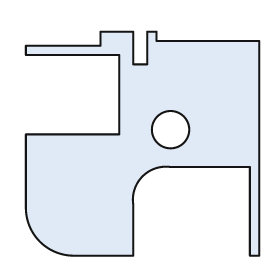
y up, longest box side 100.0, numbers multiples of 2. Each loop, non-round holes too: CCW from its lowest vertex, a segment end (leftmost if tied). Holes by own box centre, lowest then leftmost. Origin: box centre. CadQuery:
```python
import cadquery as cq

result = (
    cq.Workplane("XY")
    .moveTo(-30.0, -48.0)
    .lineTo(-4.0, -48.0)
    .lineTo(-4.0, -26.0)
    .threePointArc((0.0, -14.0), (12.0, -10.0))
    .lineTo(46.0, -10.0)
    .lineTo(46.0, -48.0)
    .lineTo(50.0, -48.0)
    .lineTo(50.0, 44.0)
    .lineTo(6.0, 44.0)
    .lineTo(6.0, 48.0)
    .lineTo(2.0, 48.0)
    .lineTo(2.0, 34.0)
    .lineTo(-4.0, 34.0)
    .lineTo(-4.0, 48.0)
    .lineTo(-18.0, 48.0)
    .lineTo(-18.0, 42.0)
    .lineTo(-50.0, 42.0)
    .lineTo(-50.0, 38.0)
    .lineTo(-10.0, 38.0)
    .lineTo(-10.0, 4.0)
    .lineTo(-50.0, 4.0)
    .lineTo(-50.0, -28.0)
    .threePointArc((-44.0, -42.0), (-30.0, -48.0))
    .close()
    .moveTo(12.0, 6.0)
    .circle(8.0)
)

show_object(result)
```